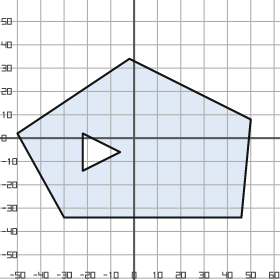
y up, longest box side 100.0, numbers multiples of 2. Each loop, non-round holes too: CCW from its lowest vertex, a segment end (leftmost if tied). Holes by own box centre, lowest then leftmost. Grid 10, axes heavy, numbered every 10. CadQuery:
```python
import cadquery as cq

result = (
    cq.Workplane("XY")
    .moveTo(-30.0, -34.0)
    .lineTo(46.0, -34.0)
    .lineTo(50.0, 8.0)
    .lineTo(-2.0, 34.0)
    .lineTo(-50.0, 2.0)
    .close()
    .moveTo(-22.0, -14.0)
    .lineTo(-6.0, -6.0)
    .lineTo(-22.0, 2.0)
    .close()
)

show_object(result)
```